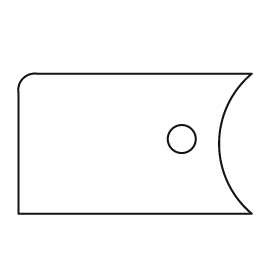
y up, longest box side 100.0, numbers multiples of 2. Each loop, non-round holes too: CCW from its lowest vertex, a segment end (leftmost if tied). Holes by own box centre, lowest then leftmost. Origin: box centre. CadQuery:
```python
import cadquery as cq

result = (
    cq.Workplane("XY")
    .moveTo(-50.0, -30.0)
    .lineTo(50.0, -30.0)
    .threePointArc((36.0, 0.0), (50.0, 30.0))
    .lineTo(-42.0, 30.0)
    .threePointArc((-48.0, 28.0), (-50.0, 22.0))
    .close()
    .moveTo(20.0, 2.0)
    .circle(6.0)
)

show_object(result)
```